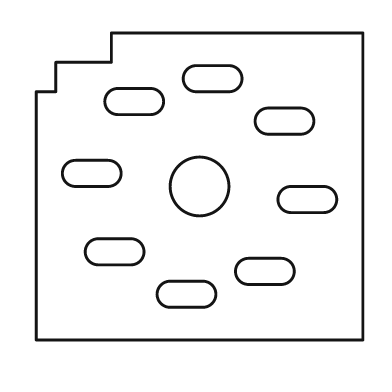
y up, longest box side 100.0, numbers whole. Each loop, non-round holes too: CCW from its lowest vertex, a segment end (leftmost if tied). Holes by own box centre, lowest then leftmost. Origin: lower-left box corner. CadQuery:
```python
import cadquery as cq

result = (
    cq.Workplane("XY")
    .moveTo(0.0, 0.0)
    .lineTo(100.0, 0.0)
    .lineTo(100.0, 94.0)
    .lineTo(23.0, 94.0)
    .lineTo(23.0, 85.0)
    .lineTo(6.0, 85.0)
    .lineTo(6.0, 76.0)
    .lineTo(0.0, 76.0)
    .close()
    .moveTo(41.0, 10.0)
    .lineTo(51.0, 10.0)
    .threePointArc((55.0, 14.0), (51.0, 18.0))
    .lineTo(41.0, 18.0)
    .threePointArc((37.0, 14.0), (41.0, 10.0))
    .close()
    .moveTo(65.0, 17.0)
    .lineTo(75.0, 17.0)
    .threePointArc((79.0, 21.0), (75.0, 25.0))
    .lineTo(65.0, 25.0)
    .threePointArc((61.0, 21.0), (65.0, 17.0))
    .close()
    .moveTo(19.0, 23.0)
    .lineTo(29.0, 23.0)
    .threePointArc((33.0, 27.0), (29.0, 31.0))
    .lineTo(19.0, 31.0)
    .threePointArc((15.0, 27.0), (19.0, 23.0))
    .close()
    .moveTo(78.0, 39.0)
    .lineTo(88.0, 39.0)
    .threePointArc((92.0, 43.0), (88.0, 47.0))
    .lineTo(78.0, 47.0)
    .threePointArc((74.0, 43.0), (78.0, 39.0))
    .close()
    .moveTo(50.0, 47.0)
    .circle(9.0)
    .moveTo(12.0, 47.0)
    .lineTo(22.0, 47.0)
    .threePointArc((26.0, 51.0), (22.0, 55.0))
    .lineTo(12.0, 55.0)
    .threePointArc((8.0, 51.0), (12.0, 47.0))
    .close()
    .moveTo(71.0, 63.0)
    .lineTo(81.0, 63.0)
    .threePointArc((85.0, 67.0), (81.0, 71.0))
    .lineTo(71.0, 71.0)
    .threePointArc((67.0, 67.0), (71.0, 63.0))
    .close()
    .moveTo(25.0, 69.0)
    .lineTo(35.0, 69.0)
    .threePointArc((39.0, 73.0), (35.0, 77.0))
    .lineTo(25.0, 77.0)
    .threePointArc((21.0, 73.0), (25.0, 69.0))
    .close()
    .moveTo(49.0, 76.0)
    .lineTo(59.0, 76.0)
    .threePointArc((63.0, 80.0), (59.0, 84.0))
    .lineTo(49.0, 84.0)
    .threePointArc((45.0, 80.0), (49.0, 76.0))
    .close()
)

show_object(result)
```